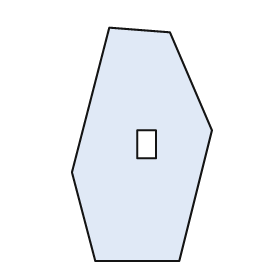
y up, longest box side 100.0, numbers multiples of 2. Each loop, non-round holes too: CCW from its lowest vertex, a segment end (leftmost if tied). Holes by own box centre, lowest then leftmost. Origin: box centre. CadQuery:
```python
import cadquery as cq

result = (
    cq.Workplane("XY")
    .moveTo(-20.0, -50.0)
    .lineTo(16.0, -50.0)
    .lineTo(30.0, 6.0)
    .lineTo(12.0, 48.0)
    .lineTo(-14.0, 50.0)
    .lineTo(-30.0, -12.0)
    .close()
    .moveTo(-2.0, -6.0)
    .lineTo(6.0, -6.0)
    .lineTo(6.0, 6.0)
    .lineTo(-2.0, 6.0)
    .close()
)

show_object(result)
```